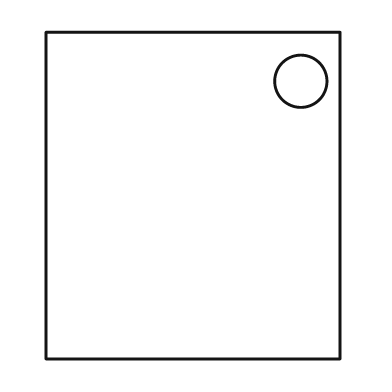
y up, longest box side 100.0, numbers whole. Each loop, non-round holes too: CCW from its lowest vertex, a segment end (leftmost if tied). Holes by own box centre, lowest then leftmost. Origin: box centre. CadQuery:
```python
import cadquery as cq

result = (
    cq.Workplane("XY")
    .moveTo(-45.0, -50.0)
    .lineTo(45.0, -50.0)
    .lineTo(45.0, 50.0)
    .lineTo(-45.0, 50.0)
    .close()
    .moveTo(33.0, 35.0)
    .circle(8.0)
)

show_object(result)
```